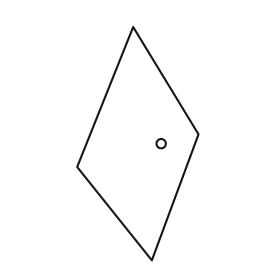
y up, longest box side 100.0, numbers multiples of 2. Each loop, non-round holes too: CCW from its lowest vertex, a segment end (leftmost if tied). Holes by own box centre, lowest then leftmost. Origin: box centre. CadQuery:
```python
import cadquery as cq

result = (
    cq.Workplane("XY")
    .moveTo(6.0, -50.0)
    .lineTo(26.0, 4.0)
    .lineTo(-2.0, 50.0)
    .lineTo(-26.0, -10.0)
    .close()
    .moveTo(10.0, 0.0)
    .circle(2.0)
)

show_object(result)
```